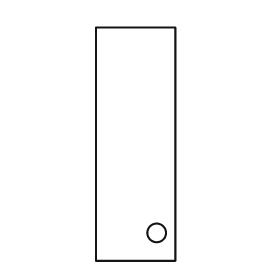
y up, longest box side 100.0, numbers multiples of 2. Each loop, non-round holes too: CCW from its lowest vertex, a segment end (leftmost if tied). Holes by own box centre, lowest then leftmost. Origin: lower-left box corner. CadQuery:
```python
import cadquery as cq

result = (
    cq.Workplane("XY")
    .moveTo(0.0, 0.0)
    .lineTo(34.0, 0.0)
    .lineTo(34.0, 100.0)
    .lineTo(0.0, 100.0)
    .close()
    .moveTo(26.0, 12.0)
    .circle(4.0)
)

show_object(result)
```